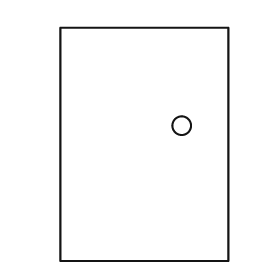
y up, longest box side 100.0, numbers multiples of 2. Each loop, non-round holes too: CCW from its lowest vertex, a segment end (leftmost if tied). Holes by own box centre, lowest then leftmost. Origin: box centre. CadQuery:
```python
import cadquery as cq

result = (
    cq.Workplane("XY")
    .moveTo(-36.0, -50.0)
    .lineTo(36.0, -50.0)
    .lineTo(36.0, 50.0)
    .lineTo(-36.0, 50.0)
    .close()
    .moveTo(16.0, 8.0)
    .circle(4.0)
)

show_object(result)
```